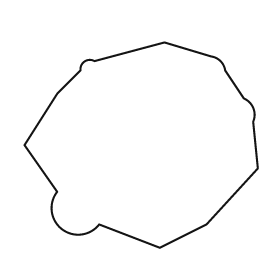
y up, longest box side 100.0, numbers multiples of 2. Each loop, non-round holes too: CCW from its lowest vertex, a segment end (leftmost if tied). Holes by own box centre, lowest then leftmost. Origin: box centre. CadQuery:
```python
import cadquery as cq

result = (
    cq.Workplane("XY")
    .moveTo(8.0, -44.0)
    .lineTo(28.0, -34.0)
    .lineTo(50.0, -10.0)
    .lineTo(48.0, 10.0)
    .threePointArc((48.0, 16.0), (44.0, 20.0))
    .lineTo(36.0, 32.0)
    .threePointArc((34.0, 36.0), (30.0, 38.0))
    .lineTo(10.0, 44.0)
    .lineTo(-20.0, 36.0)
    .threePointArc((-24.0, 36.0), (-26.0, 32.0))
    .lineTo(-36.0, 22.0)
    .lineTo(-50.0, 0.0)
    .lineTo(-36.0, -20.0)
    .threePointArc((-34.0, -36.0), (-18.0, -34.0))
    .close()
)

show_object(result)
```